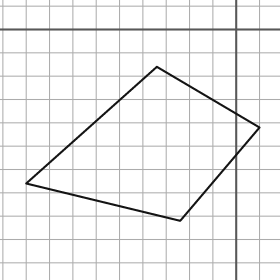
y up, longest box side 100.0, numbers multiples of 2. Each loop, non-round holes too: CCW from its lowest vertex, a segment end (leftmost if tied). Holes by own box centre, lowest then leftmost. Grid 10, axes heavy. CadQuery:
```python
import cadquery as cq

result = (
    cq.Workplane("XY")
    .moveTo(-24.0, -82.0)
    .lineTo(10.0, -42.0)
    .lineTo(-34.0, -16.0)
    .lineTo(-90.0, -66.0)
    .close()
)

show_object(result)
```